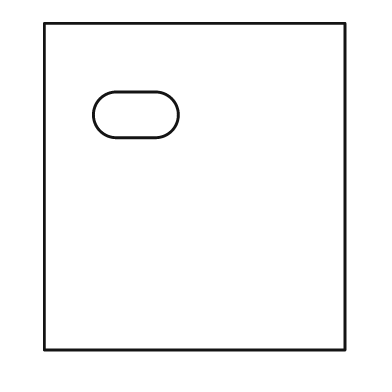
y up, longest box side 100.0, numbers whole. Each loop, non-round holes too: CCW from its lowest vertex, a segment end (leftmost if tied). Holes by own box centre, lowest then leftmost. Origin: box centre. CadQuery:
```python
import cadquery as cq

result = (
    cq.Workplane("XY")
    .moveTo(-46.0, -50.0)
    .lineTo(46.0, -50.0)
    .lineTo(46.0, 50.0)
    .lineTo(-46.0, 50.0)
    .close()
    .moveTo(-24.0, 15.0)
    .lineTo(-12.0, 15.0)
    .threePointArc((-5.0, 22.0), (-12.0, 29.0))
    .lineTo(-24.0, 29.0)
    .threePointArc((-31.0, 22.0), (-24.0, 15.0))
    .close()
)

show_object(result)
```